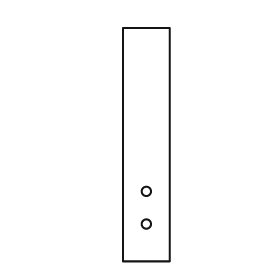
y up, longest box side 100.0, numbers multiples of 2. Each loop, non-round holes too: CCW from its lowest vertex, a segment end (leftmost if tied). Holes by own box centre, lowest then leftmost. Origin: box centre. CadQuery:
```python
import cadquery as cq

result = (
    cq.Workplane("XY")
    .moveTo(-10.0, -50.0)
    .lineTo(10.0, -50.0)
    .lineTo(10.0, 50.0)
    .lineTo(-10.0, 50.0)
    .close()
    .moveTo(0.0, -34.0)
    .circle(2.0)
    .moveTo(0.0, -20.0)
    .circle(2.0)
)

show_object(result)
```